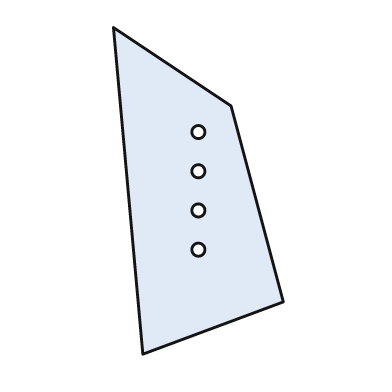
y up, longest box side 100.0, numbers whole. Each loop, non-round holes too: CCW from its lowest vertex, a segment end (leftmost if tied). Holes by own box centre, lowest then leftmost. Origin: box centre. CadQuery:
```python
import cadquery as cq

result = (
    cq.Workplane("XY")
    .moveTo(-17.0, -50.0)
    .lineTo(26.0, -34.0)
    .lineTo(10.0, 26.0)
    .lineTo(-26.0, 50.0)
    .close()
    .moveTo(0.0, -18.0)
    .circle(2.0)
    .moveTo(0.0, -6.0)
    .circle(2.0)
    .moveTo(0.0, 6.0)
    .circle(2.0)
    .moveTo(0.0, 18.0)
    .circle(2.0)
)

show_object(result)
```